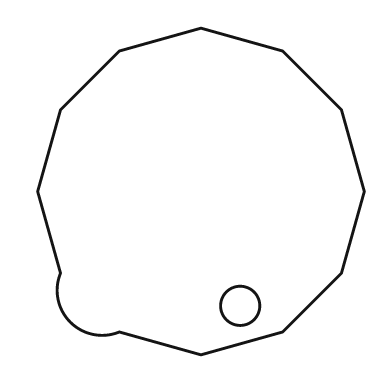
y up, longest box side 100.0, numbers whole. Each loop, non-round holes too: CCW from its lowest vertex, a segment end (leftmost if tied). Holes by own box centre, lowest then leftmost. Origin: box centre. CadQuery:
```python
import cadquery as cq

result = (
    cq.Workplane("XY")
    .moveTo(0.0, -50.0)
    .lineTo(25.0, -43.0)
    .lineTo(43.0, -25.0)
    .lineTo(50.0, 0.0)
    .lineTo(43.0, 25.0)
    .lineTo(25.0, 43.0)
    .lineTo(0.0, 50.0)
    .lineTo(-25.0, 43.0)
    .lineTo(-43.0, 25.0)
    .lineTo(-50.0, 0.0)
    .lineTo(-43.0, -25.0)
    .threePointArc((-40.0, -40.0), (-25.0, -43.0))
    .close()
    .moveTo(12.0, -35.0)
    .circle(6.0)
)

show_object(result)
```